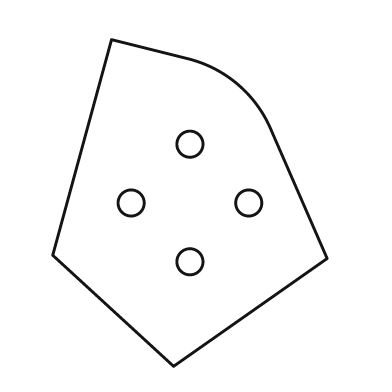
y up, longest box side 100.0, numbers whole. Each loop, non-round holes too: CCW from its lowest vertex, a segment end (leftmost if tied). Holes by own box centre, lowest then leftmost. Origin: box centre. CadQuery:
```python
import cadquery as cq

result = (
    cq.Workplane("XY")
    .moveTo(-5.0, -50.0)
    .lineTo(42.0, -17.0)
    .lineTo(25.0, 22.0)
    .threePointArc((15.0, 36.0), (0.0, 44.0))
    .lineTo(-24.0, 50.0)
    .lineTo(-42.0, -16.0)
    .close()
    .moveTo(0.0, -18.0)
    .circle(4.0)
    .moveTo(-18.0, 0.0)
    .circle(4.0)
    .moveTo(18.0, 0.0)
    .circle(4.0)
    .moveTo(0.0, 18.0)
    .circle(4.0)
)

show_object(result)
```